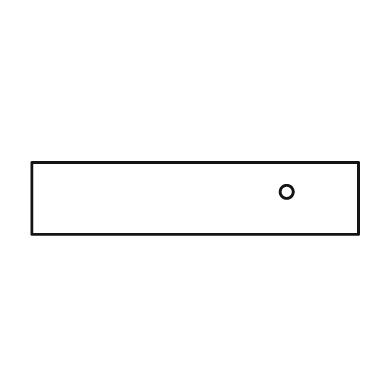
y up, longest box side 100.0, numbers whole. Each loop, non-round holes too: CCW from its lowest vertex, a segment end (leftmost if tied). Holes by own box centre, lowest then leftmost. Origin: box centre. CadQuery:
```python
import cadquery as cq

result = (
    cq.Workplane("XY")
    .moveTo(-50.0, -11.0)
    .lineTo(50.0, -11.0)
    .lineTo(50.0, 11.0)
    .lineTo(-50.0, 11.0)
    .close()
    .moveTo(28.0, 2.0)
    .circle(2.0)
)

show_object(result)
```